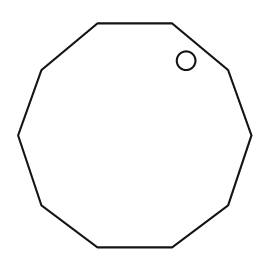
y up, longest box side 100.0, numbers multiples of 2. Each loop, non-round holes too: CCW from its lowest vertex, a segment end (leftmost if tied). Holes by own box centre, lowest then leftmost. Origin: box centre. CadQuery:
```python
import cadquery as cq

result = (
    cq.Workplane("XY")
    .moveTo(-16.0, -48.0)
    .lineTo(16.0, -48.0)
    .lineTo(40.0, -30.0)
    .lineTo(50.0, 0.0)
    .lineTo(40.0, 28.0)
    .lineTo(16.0, 48.0)
    .lineTo(-16.0, 48.0)
    .lineTo(-40.0, 28.0)
    .lineTo(-50.0, 0.0)
    .lineTo(-40.0, -30.0)
    .close()
    .moveTo(22.0, 32.0)
    .circle(4.0)
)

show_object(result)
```